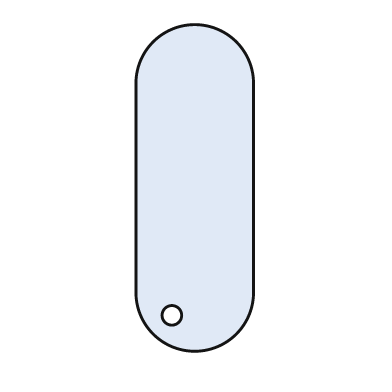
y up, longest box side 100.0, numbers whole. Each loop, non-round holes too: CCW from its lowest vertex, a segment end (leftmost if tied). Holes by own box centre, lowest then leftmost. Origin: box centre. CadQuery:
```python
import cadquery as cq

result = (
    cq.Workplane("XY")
    .moveTo(-18.0, -32.0)
    .threePointArc((0.0, -50.0), (18.0, -32.0))
    .lineTo(18.0, 32.0)
    .threePointArc((0.0, 50.0), (-18.0, 32.0))
    .close()
    .moveTo(-7.0, -39.0)
    .circle(3.0)
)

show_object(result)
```